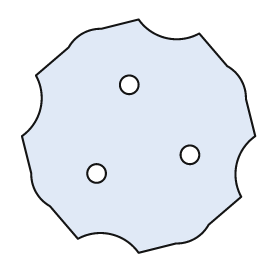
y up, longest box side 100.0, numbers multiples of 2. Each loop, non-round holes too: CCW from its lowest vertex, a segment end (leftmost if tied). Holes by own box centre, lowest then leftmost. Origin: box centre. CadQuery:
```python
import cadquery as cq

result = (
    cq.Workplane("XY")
    .moveTo(0.0, -50.0)
    .lineTo(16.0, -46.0)
    .threePointArc((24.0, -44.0), (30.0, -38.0))
    .lineTo(44.0, -26.0)
    .threePointArc((42.0, -12.0), (50.0, 0.0))
    .lineTo(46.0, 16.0)
    .threePointArc((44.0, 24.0), (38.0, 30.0))
    .lineTo(26.0, 44.0)
    .threePointArc((12.0, 42.0), (0.0, 50.0))
    .lineTo(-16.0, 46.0)
    .threePointArc((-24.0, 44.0), (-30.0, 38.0))
    .lineTo(-44.0, 26.0)
    .threePointArc((-42.0, 12.0), (-50.0, 0.0))
    .lineTo(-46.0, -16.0)
    .threePointArc((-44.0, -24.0), (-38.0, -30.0))
    .lineTo(-26.0, -44.0)
    .threePointArc((-12.0, -42.0), (0.0, -50.0))
    .close()
    .moveTo(-18.0, -16.0)
    .circle(4.0)
    .moveTo(22.0, -8.0)
    .circle(4.0)
    .moveTo(-4.0, 22.0)
    .circle(4.0)
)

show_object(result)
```